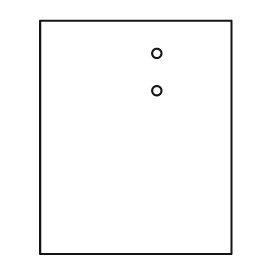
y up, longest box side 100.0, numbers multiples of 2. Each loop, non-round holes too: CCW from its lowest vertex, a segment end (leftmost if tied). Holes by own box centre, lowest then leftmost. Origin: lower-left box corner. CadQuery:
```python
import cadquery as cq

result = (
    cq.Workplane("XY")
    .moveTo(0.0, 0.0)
    .lineTo(82.0, 0.0)
    .lineTo(82.0, 100.0)
    .lineTo(0.0, 100.0)
    .close()
    .moveTo(50.0, 70.0)
    .circle(2.0)
    .moveTo(50.0, 86.0)
    .circle(2.0)
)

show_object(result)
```